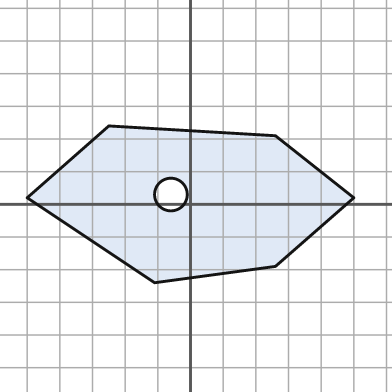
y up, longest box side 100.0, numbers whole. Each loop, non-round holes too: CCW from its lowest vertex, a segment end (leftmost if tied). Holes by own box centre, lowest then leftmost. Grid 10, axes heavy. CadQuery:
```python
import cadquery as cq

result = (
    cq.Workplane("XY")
    .moveTo(-11.0, -24.0)
    .lineTo(26.0, -19.0)
    .lineTo(50.0, 2.0)
    .lineTo(26.0, 21.0)
    .lineTo(-25.0, 24.0)
    .lineTo(-50.0, 2.0)
    .close()
    .moveTo(-6.0, 3.0)
    .circle(5.0)
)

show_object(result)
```